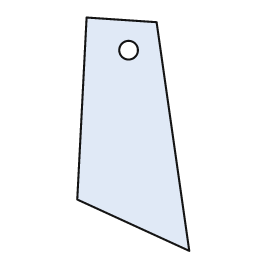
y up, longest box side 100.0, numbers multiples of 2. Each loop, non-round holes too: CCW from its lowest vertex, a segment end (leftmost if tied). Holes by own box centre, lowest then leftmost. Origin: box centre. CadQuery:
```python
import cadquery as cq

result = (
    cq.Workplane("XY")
    .moveTo(24.0, -50.0)
    .lineTo(10.0, 48.0)
    .lineTo(-20.0, 50.0)
    .lineTo(-24.0, -28.0)
    .close()
    .moveTo(-2.0, 36.0)
    .circle(4.0)
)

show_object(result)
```